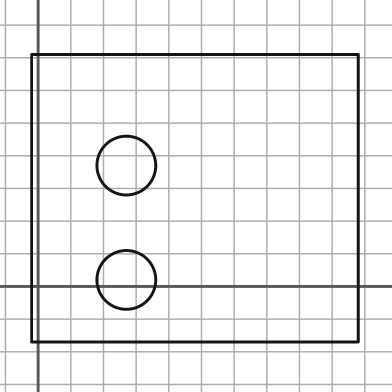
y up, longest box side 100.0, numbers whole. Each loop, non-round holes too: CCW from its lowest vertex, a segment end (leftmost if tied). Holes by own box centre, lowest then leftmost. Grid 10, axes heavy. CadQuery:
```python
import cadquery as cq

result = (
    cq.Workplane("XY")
    .moveTo(-2.0, -17.0)
    .lineTo(98.0, -17.0)
    .lineTo(98.0, 71.0)
    .lineTo(-2.0, 71.0)
    .close()
    .moveTo(27.0, 2.0)
    .circle(9.0)
    .moveTo(27.0, 37.0)
    .circle(9.0)
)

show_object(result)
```